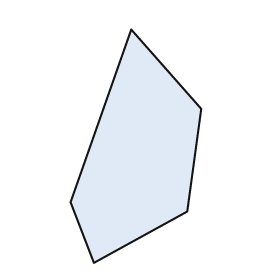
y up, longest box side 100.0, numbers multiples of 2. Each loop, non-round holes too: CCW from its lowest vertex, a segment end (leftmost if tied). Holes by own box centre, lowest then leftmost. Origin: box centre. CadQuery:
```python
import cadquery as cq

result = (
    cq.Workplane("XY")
    .moveTo(-18.0, -50.0)
    .lineTo(22.0, -28.0)
    .lineTo(28.0, 16.0)
    .lineTo(-2.0, 50.0)
    .lineTo(-28.0, -24.0)
    .close()
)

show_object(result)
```